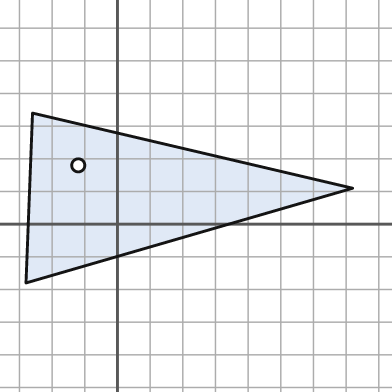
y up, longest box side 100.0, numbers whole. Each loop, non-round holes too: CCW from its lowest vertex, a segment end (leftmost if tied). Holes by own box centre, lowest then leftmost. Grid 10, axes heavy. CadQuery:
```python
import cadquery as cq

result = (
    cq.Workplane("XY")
    .moveTo(-28.0, -18.0)
    .lineTo(72.0, 11.0)
    .lineTo(-26.0, 34.0)
    .close()
    .moveTo(-12.0, 18.0)
    .circle(2.0)
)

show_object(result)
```